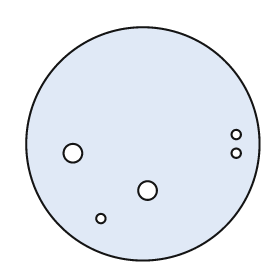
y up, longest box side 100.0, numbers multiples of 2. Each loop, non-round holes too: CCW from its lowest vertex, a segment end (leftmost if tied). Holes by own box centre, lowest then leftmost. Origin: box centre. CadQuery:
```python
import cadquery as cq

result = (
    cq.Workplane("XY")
    .moveTo(0.0, 0.0)
    .circle(50.0)
    .moveTo(-18.0, -32.0)
    .circle(2.0)
    .moveTo(2.0, -20.0)
    .circle(4.0)
    .moveTo(-30.0, -4.0)
    .circle(4.0)
    .moveTo(40.0, -4.0)
    .circle(2.0)
    .moveTo(40.0, 4.0)
    .circle(2.0)
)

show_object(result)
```